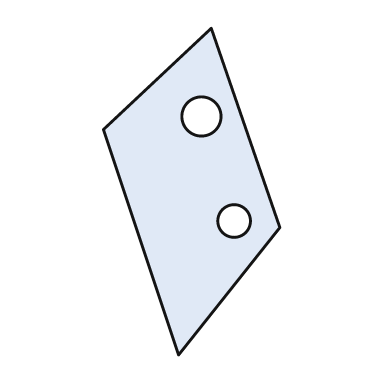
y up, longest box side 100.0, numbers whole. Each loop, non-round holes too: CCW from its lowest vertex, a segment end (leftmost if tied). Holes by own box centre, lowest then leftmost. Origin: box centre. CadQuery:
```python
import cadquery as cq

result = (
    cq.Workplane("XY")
    .moveTo(-4.0, -50.0)
    .lineTo(27.0, -11.0)
    .lineTo(6.0, 50.0)
    .lineTo(-27.0, 19.0)
    .close()
    .moveTo(13.0, -9.0)
    .circle(5.0)
    .moveTo(3.0, 23.0)
    .circle(6.0)
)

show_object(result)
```